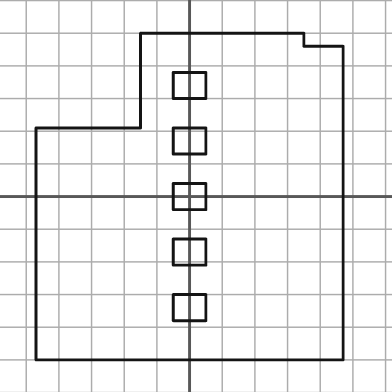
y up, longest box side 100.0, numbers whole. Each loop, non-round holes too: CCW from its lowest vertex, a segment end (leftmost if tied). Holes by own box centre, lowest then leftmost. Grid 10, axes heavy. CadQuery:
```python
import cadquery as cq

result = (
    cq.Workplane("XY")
    .moveTo(-47.0, -50.0)
    .lineTo(47.0, -50.0)
    .lineTo(47.0, 46.0)
    .lineTo(35.0, 46.0)
    .lineTo(35.0, 50.0)
    .lineTo(-15.0, 50.0)
    .lineTo(-15.0, 21.0)
    .lineTo(-47.0, 21.0)
    .close()
    .moveTo(-5.0, -38.0)
    .lineTo(5.0, -38.0)
    .lineTo(5.0, -30.0)
    .lineTo(-5.0, -30.0)
    .close()
    .moveTo(-5.0, -21.0)
    .lineTo(5.0, -21.0)
    .lineTo(5.0, -13.0)
    .lineTo(-5.0, -13.0)
    .close()
    .moveTo(-5.0, -4.0)
    .lineTo(5.0, -4.0)
    .lineTo(5.0, 4.0)
    .lineTo(-5.0, 4.0)
    .close()
    .moveTo(-5.0, 13.0)
    .lineTo(5.0, 13.0)
    .lineTo(5.0, 21.0)
    .lineTo(-5.0, 21.0)
    .close()
    .moveTo(-5.0, 30.0)
    .lineTo(5.0, 30.0)
    .lineTo(5.0, 38.0)
    .lineTo(-5.0, 38.0)
    .close()
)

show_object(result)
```